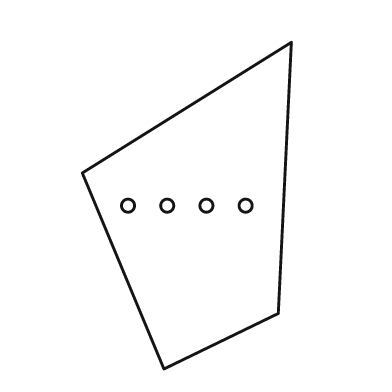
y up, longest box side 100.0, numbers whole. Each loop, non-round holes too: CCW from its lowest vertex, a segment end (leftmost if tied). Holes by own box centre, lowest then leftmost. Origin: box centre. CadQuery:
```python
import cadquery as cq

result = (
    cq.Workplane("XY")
    .moveTo(-7.0, -50.0)
    .lineTo(28.0, -33.0)
    .lineTo(32.0, 50.0)
    .lineTo(-32.0, 10.0)
    .close()
    .moveTo(-18.0, 0.0)
    .circle(2.0)
    .moveTo(-6.0, 0.0)
    .circle(2.0)
    .moveTo(6.0, 0.0)
    .circle(2.0)
    .moveTo(18.0, 0.0)
    .circle(2.0)
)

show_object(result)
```